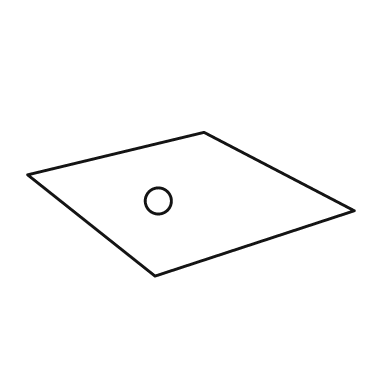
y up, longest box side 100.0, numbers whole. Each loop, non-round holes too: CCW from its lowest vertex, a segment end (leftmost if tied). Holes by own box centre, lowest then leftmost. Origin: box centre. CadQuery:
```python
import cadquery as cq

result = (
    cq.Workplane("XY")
    .moveTo(-11.0, -22.0)
    .lineTo(50.0, -2.0)
    .lineTo(4.0, 22.0)
    .lineTo(-50.0, 9.0)
    .close()
    .moveTo(-10.0, 1.0)
    .circle(4.0)
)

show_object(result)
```